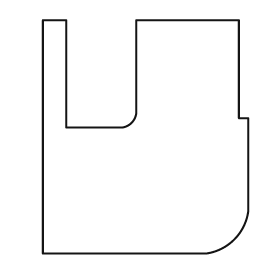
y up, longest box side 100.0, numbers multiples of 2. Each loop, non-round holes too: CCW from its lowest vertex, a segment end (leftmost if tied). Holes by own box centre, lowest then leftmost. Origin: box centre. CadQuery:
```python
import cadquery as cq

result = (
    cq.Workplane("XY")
    .moveTo(-44.0, -50.0)
    .lineTo(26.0, -50.0)
    .threePointArc((38.0, -44.0), (44.0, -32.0))
    .lineTo(44.0, 8.0)
    .lineTo(40.0, 8.0)
    .lineTo(40.0, 50.0)
    .lineTo(-4.0, 50.0)
    .lineTo(-4.0, 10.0)
    .threePointArc((-6.0, 6.0), (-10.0, 4.0))
    .lineTo(-34.0, 4.0)
    .lineTo(-34.0, 50.0)
    .lineTo(-44.0, 50.0)
    .close()
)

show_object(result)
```